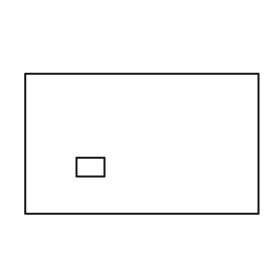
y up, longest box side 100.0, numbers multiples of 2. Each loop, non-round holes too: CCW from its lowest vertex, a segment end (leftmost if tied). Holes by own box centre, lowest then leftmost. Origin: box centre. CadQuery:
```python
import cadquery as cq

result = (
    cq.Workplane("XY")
    .moveTo(-50.0, -30.0)
    .lineTo(50.0, -30.0)
    .lineTo(50.0, 30.0)
    .lineTo(-50.0, 30.0)
    .close()
    .moveTo(-28.0, -14.0)
    .lineTo(-16.0, -14.0)
    .lineTo(-16.0, -6.0)
    .lineTo(-28.0, -6.0)
    .close()
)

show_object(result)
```